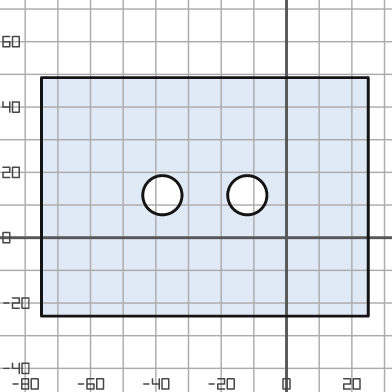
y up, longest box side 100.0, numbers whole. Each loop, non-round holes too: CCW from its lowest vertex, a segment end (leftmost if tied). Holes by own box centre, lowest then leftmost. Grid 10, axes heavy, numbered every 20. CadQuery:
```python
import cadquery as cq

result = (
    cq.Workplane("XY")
    .moveTo(-75.0, -24.0)
    .lineTo(25.0, -24.0)
    .lineTo(25.0, 49.0)
    .lineTo(-75.0, 49.0)
    .close()
    .moveTo(-38.0, 13.0)
    .circle(6.0)
    .moveTo(-12.0, 13.0)
    .circle(6.0)
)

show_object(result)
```